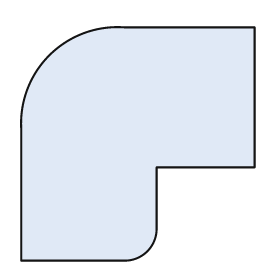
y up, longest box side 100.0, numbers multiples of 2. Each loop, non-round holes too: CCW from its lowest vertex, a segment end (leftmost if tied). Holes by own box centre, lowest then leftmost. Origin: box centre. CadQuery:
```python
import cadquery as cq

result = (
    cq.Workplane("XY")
    .moveTo(-50.0, -50.0)
    .lineTo(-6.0, -50.0)
    .threePointArc((4.0, -46.0), (8.0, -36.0))
    .lineTo(8.0, -10.0)
    .lineTo(50.0, -10.0)
    .lineTo(50.0, 50.0)
    .lineTo(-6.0, 50.0)
    .threePointArc((-38.0, 38.0), (-50.0, 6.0))
    .close()
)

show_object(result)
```